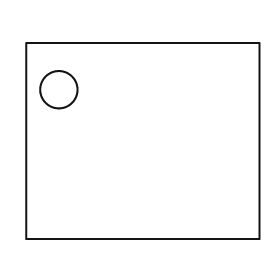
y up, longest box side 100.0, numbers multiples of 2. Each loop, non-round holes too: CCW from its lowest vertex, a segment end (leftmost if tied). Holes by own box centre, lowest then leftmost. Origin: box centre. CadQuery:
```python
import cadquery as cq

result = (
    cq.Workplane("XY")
    .moveTo(-50.0, -42.0)
    .lineTo(50.0, -42.0)
    .lineTo(50.0, 42.0)
    .lineTo(-50.0, 42.0)
    .close()
    .moveTo(-36.0, 22.0)
    .circle(8.0)
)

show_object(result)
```